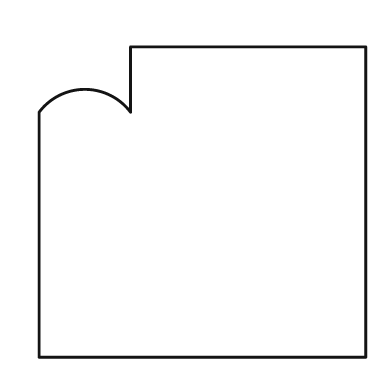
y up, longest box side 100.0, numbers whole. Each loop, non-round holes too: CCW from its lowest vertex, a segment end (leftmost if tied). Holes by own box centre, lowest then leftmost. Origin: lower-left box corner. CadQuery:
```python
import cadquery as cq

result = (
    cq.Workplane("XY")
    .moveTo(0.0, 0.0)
    .lineTo(100.0, 0.0)
    .lineTo(100.0, 95.0)
    .lineTo(28.0, 95.0)
    .lineTo(28.0, 75.0)
    .threePointArc((14.0, 82.0), (0.0, 75.0))
    .close()
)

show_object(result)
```